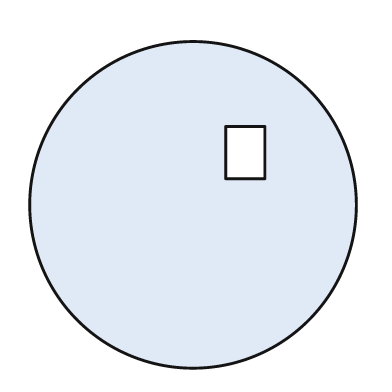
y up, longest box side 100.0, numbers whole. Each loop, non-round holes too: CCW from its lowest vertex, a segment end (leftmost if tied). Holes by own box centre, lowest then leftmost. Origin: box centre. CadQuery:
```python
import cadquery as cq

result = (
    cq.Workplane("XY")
    .moveTo(0.0, 0.0)
    .circle(50.0)
    .moveTo(10.0, 8.0)
    .lineTo(22.0, 8.0)
    .lineTo(22.0, 24.0)
    .lineTo(10.0, 24.0)
    .close()
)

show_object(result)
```